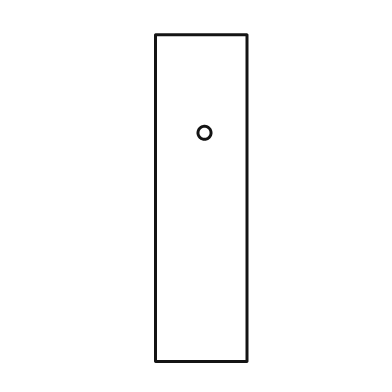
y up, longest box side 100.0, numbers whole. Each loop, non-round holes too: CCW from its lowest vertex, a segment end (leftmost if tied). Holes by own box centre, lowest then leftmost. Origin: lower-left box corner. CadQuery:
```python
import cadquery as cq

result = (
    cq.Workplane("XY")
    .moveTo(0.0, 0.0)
    .lineTo(28.0, 0.0)
    .lineTo(28.0, 100.0)
    .lineTo(0.0, 100.0)
    .close()
    .moveTo(15.0, 70.0)
    .circle(2.0)
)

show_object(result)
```